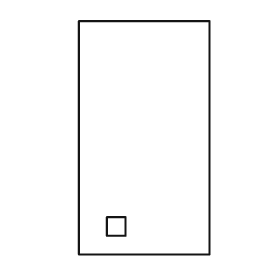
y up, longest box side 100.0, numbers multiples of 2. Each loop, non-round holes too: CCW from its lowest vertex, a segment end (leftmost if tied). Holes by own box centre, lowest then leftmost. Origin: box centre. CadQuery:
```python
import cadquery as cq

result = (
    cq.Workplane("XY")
    .moveTo(-28.0, -50.0)
    .lineTo(28.0, -50.0)
    .lineTo(28.0, 50.0)
    .lineTo(-28.0, 50.0)
    .close()
    .moveTo(-16.0, -42.0)
    .lineTo(-8.0, -42.0)
    .lineTo(-8.0, -34.0)
    .lineTo(-16.0, -34.0)
    .close()
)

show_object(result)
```